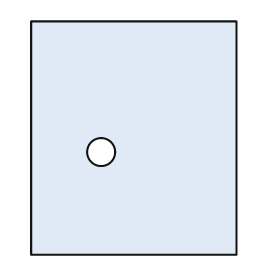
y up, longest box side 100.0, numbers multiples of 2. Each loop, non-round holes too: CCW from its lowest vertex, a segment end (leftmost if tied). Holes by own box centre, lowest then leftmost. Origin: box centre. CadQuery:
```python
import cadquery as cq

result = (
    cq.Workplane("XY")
    .moveTo(-44.0, -50.0)
    .lineTo(44.0, -50.0)
    .lineTo(44.0, 50.0)
    .lineTo(-44.0, 50.0)
    .close()
    .moveTo(-14.0, -6.0)
    .circle(6.0)
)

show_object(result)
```